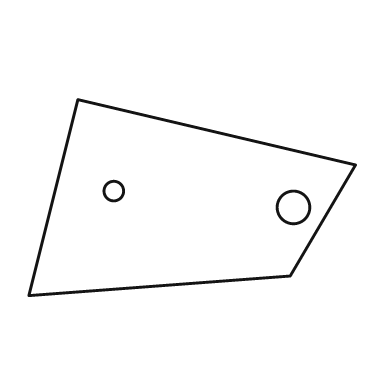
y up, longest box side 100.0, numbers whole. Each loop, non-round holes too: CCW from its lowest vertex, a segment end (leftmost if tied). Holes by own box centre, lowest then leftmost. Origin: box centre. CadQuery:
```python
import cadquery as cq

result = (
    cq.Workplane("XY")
    .moveTo(-50.0, -30.0)
    .lineTo(30.0, -24.0)
    .lineTo(50.0, 10.0)
    .lineTo(-35.0, 30.0)
    .close()
    .moveTo(31.0, -3.0)
    .circle(5.0)
    .moveTo(-24.0, 2.0)
    .circle(3.0)
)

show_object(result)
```